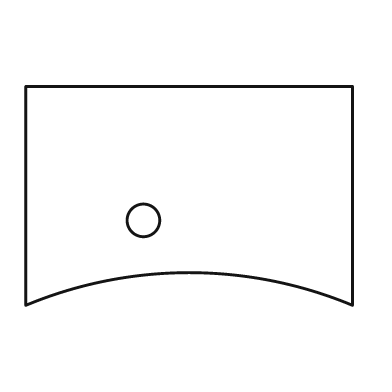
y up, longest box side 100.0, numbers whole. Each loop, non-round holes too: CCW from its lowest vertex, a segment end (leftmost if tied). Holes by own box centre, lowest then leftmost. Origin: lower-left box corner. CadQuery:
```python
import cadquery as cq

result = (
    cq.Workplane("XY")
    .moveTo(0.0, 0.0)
    .threePointArc((50.0, 10.0), (100.0, 0.0))
    .lineTo(100.0, 67.0)
    .lineTo(0.0, 67.0)
    .close()
    .moveTo(36.0, 26.0)
    .circle(5.0)
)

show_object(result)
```